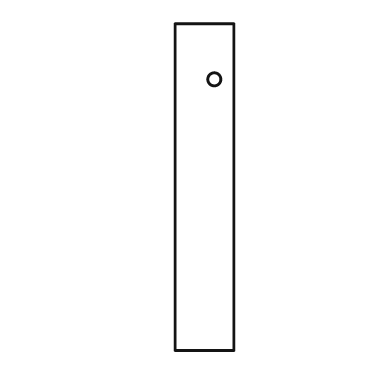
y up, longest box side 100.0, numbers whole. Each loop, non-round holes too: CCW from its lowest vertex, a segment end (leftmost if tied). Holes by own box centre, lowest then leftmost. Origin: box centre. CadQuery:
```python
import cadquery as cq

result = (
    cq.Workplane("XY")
    .moveTo(-9.0, -50.0)
    .lineTo(9.0, -50.0)
    .lineTo(9.0, 50.0)
    .lineTo(-9.0, 50.0)
    .close()
    .moveTo(3.0, 33.0)
    .circle(2.0)
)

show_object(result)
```